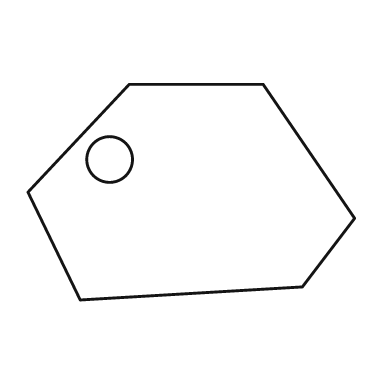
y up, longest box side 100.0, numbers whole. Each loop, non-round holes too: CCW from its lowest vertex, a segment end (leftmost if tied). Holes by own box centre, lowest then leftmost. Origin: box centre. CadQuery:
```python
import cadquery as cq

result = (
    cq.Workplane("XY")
    .moveTo(-34.0, -33.0)
    .lineTo(34.0, -29.0)
    .lineTo(50.0, -8.0)
    .lineTo(22.0, 33.0)
    .lineTo(-19.0, 33.0)
    .lineTo(-50.0, 0.0)
    .close()
    .moveTo(-25.0, 10.0)
    .circle(7.0)
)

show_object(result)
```